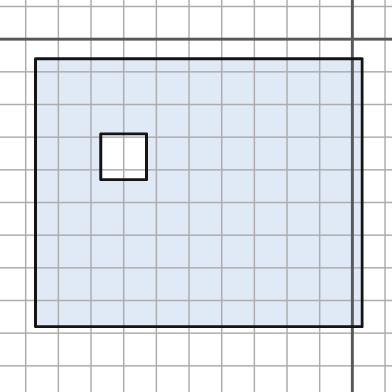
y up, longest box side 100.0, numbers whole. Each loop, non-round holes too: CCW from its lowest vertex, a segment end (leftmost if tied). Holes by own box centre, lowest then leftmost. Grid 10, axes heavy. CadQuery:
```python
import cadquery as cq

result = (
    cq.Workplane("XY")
    .moveTo(-97.0, -88.0)
    .lineTo(3.0, -88.0)
    .lineTo(3.0, -6.0)
    .lineTo(-97.0, -6.0)
    .close()
    .moveTo(-77.0, -43.0)
    .lineTo(-63.0, -43.0)
    .lineTo(-63.0, -29.0)
    .lineTo(-77.0, -29.0)
    .close()
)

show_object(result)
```